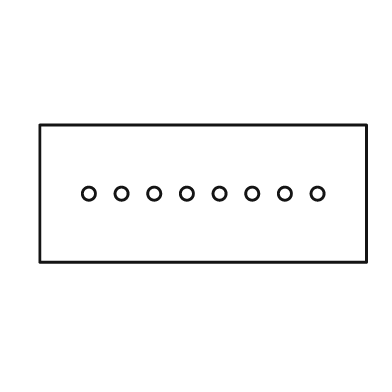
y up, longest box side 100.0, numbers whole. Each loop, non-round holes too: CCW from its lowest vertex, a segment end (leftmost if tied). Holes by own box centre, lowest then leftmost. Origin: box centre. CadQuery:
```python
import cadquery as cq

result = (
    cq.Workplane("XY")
    .moveTo(-50.0, -21.0)
    .lineTo(50.0, -21.0)
    .lineTo(50.0, 21.0)
    .lineTo(-50.0, 21.0)
    .close()
    .moveTo(-35.0, 0.0)
    .circle(2.0)
    .moveTo(-25.0, 0.0)
    .circle(2.0)
    .moveTo(-15.0, 0.0)
    .circle(2.0)
    .moveTo(-5.0, 0.0)
    .circle(2.0)
    .moveTo(5.0, 0.0)
    .circle(2.0)
    .moveTo(15.0, 0.0)
    .circle(2.0)
    .moveTo(25.0, 0.0)
    .circle(2.0)
    .moveTo(35.0, 0.0)
    .circle(2.0)
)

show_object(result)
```